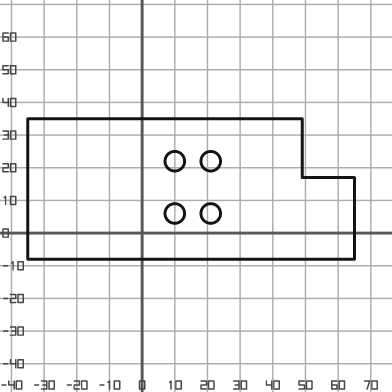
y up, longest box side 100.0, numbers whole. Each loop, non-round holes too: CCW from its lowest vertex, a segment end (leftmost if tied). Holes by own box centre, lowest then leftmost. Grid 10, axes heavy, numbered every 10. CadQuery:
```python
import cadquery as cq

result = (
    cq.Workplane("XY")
    .moveTo(-35.0, -8.0)
    .lineTo(65.0, -8.0)
    .lineTo(65.0, 17.0)
    .lineTo(49.0, 17.0)
    .lineTo(49.0, 35.0)
    .lineTo(-35.0, 35.0)
    .close()
    .moveTo(10.0, 6.0)
    .circle(3.0)
    .moveTo(21.0, 6.0)
    .circle(3.0)
    .moveTo(10.0, 22.0)
    .circle(3.0)
    .moveTo(21.0, 22.0)
    .circle(3.0)
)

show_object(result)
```